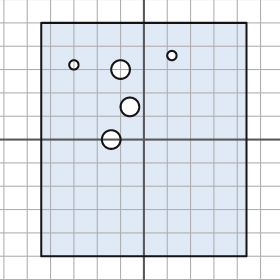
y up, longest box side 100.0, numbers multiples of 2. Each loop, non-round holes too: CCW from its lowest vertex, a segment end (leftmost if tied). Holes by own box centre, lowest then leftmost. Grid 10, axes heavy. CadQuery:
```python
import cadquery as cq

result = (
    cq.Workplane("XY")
    .moveTo(-44.0, -50.0)
    .lineTo(44.0, -50.0)
    .lineTo(44.0, 50.0)
    .lineTo(-44.0, 50.0)
    .close()
    .moveTo(-14.0, 0.0)
    .circle(4.0)
    .moveTo(-6.0, 14.0)
    .circle(4.0)
    .moveTo(-10.0, 30.0)
    .circle(4.0)
    .moveTo(-30.0, 32.0)
    .circle(2.0)
    .moveTo(12.0, 36.0)
    .circle(2.0)
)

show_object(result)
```